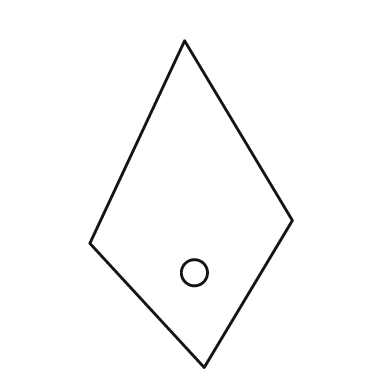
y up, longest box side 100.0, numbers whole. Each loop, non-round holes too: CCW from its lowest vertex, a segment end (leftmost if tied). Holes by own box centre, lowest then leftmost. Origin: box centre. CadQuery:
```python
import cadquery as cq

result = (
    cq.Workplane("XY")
    .moveTo(4.0, -50.0)
    .lineTo(31.0, -5.0)
    .lineTo(-2.0, 50.0)
    .lineTo(-31.0, -12.0)
    .close()
    .moveTo(1.0, -21.0)
    .circle(4.0)
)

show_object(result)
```